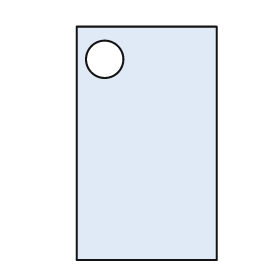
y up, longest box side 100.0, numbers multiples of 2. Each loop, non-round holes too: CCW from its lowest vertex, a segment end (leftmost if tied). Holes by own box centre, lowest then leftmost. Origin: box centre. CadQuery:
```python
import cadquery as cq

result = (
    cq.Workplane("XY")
    .moveTo(-30.0, -50.0)
    .lineTo(30.0, -50.0)
    .lineTo(30.0, 50.0)
    .lineTo(-30.0, 50.0)
    .close()
    .moveTo(-18.0, 36.0)
    .circle(8.0)
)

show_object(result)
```